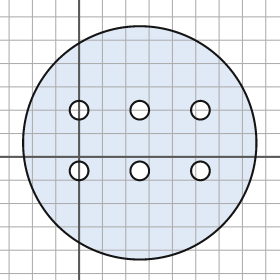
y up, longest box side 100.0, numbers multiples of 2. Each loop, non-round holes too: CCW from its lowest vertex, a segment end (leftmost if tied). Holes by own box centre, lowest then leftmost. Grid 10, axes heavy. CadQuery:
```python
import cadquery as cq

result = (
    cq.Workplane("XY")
    .moveTo(26.0, 6.0)
    .circle(50.0)
    .moveTo(0.0, -6.0)
    .circle(4.0)
    .moveTo(26.0, -6.0)
    .circle(4.0)
    .moveTo(52.0, -6.0)
    .circle(4.0)
    .moveTo(0.0, 20.0)
    .circle(4.0)
    .moveTo(26.0, 20.0)
    .circle(4.0)
    .moveTo(52.0, 20.0)
    .circle(4.0)
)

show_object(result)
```